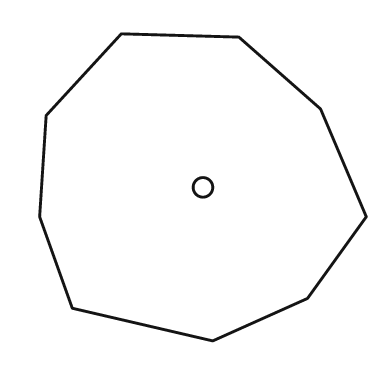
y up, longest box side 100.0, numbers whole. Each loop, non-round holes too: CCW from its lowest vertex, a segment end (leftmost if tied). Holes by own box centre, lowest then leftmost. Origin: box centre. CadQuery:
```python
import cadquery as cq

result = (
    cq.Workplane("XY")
    .moveTo(3.0, -47.0)
    .lineTo(32.0, -34.0)
    .lineTo(50.0, -9.0)
    .lineTo(36.0, 24.0)
    .lineTo(11.0, 46.0)
    .lineTo(-25.0, 47.0)
    .lineTo(-48.0, 22.0)
    .lineTo(-50.0, -9.0)
    .lineTo(-40.0, -37.0)
    .close()
    .moveTo(0.0, 0.0)
    .circle(3.0)
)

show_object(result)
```